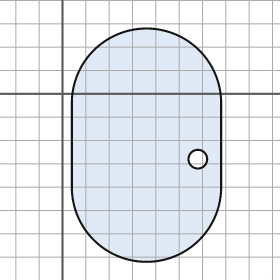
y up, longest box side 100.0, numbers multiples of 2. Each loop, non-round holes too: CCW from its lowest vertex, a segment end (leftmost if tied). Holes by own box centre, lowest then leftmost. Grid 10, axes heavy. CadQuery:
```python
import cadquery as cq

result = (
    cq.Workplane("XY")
    .moveTo(4.0, -40.0)
    .threePointArc((36.0, -72.0), (68.0, -40.0))
    .lineTo(68.0, -4.0)
    .threePointArc((36.0, 28.0), (4.0, -4.0))
    .close()
    .moveTo(58.0, -28.0)
    .circle(4.0)
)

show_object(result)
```